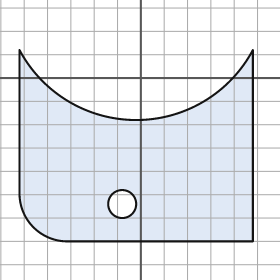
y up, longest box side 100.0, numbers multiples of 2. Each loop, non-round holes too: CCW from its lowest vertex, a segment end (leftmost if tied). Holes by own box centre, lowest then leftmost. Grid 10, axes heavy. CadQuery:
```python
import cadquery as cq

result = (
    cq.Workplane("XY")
    .moveTo(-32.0, -70.0)
    .lineTo(48.0, -70.0)
    .lineTo(48.0, 12.0)
    .threePointArc((-2.0, -18.0), (-52.0, 12.0))
    .lineTo(-52.0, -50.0)
    .threePointArc((-46.0, -64.0), (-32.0, -70.0))
    .close()
    .moveTo(-8.0, -54.0)
    .circle(6.0)
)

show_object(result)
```